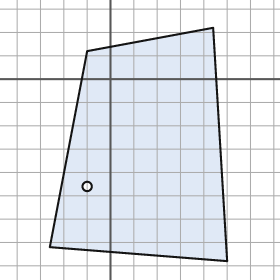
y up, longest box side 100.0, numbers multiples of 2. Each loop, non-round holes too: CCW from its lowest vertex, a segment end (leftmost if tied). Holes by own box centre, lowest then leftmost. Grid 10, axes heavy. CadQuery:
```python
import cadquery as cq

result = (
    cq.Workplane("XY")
    .moveTo(50.0, -78.0)
    .lineTo(44.0, 22.0)
    .lineTo(-10.0, 12.0)
    .lineTo(-26.0, -72.0)
    .close()
    .moveTo(-10.0, -46.0)
    .circle(2.0)
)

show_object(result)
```